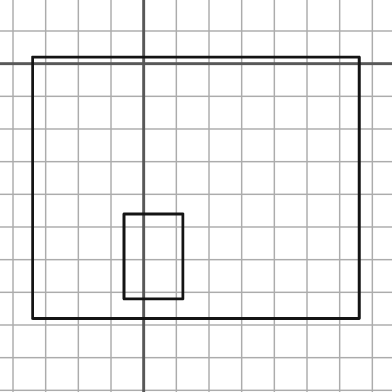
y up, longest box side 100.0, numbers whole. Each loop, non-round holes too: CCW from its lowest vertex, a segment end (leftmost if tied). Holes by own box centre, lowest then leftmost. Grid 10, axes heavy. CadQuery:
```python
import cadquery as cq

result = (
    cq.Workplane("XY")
    .moveTo(-34.0, -78.0)
    .lineTo(66.0, -78.0)
    .lineTo(66.0, 2.0)
    .lineTo(-34.0, 2.0)
    .close()
    .moveTo(-6.0, -72.0)
    .lineTo(12.0, -72.0)
    .lineTo(12.0, -46.0)
    .lineTo(-6.0, -46.0)
    .close()
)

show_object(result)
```